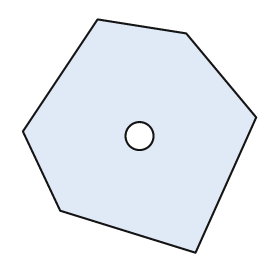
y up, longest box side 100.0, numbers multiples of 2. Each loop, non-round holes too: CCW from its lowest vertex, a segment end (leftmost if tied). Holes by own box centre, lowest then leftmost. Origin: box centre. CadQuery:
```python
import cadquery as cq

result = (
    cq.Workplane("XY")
    .moveTo(24.0, -50.0)
    .lineTo(50.0, 8.0)
    .lineTo(20.0, 44.0)
    .lineTo(-18.0, 50.0)
    .lineTo(-50.0, 2.0)
    .lineTo(-34.0, -32.0)
    .close()
    .moveTo(0.0, 0.0)
    .circle(6.0)
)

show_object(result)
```